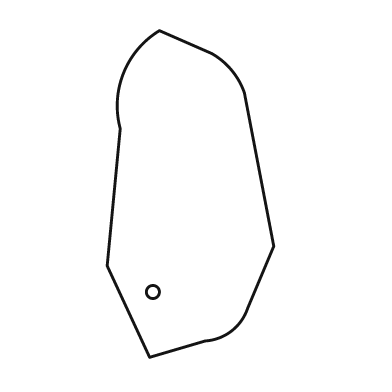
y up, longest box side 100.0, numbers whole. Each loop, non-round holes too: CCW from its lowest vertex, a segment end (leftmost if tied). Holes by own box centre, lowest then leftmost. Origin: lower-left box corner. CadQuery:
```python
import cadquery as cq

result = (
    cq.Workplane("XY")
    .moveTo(13.0, 0.0)
    .lineTo(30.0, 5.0)
    .threePointArc((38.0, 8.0), (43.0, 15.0))
    .lineTo(51.0, 34.0)
    .lineTo(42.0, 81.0)
    .threePointArc((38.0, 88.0), (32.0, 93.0))
    .lineTo(16.0, 100.0)
    .threePointArc((5.0, 87.0), (4.0, 70.0))
    .lineTo(0.0, 28.0)
    .close()
    .moveTo(14.0, 20.0)
    .circle(2.0)
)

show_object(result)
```